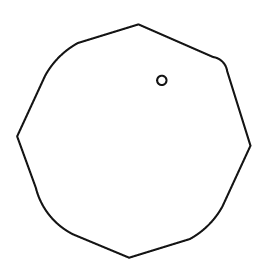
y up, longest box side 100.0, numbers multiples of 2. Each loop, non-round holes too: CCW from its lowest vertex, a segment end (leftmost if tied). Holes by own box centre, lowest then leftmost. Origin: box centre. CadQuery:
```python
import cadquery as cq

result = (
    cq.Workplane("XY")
    .moveTo(-2.0, -50.0)
    .lineTo(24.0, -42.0)
    .threePointArc((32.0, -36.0), (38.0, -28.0))
    .lineTo(50.0, -2.0)
    .lineTo(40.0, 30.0)
    .threePointArc((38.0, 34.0), (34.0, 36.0))
    .lineTo(2.0, 50.0)
    .lineTo(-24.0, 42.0)
    .threePointArc((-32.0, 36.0), (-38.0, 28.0))
    .lineTo(-50.0, 2.0)
    .lineTo(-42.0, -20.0)
    .threePointArc((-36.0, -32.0), (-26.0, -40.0))
    .close()
    .moveTo(12.0, 26.0)
    .circle(2.0)
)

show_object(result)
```